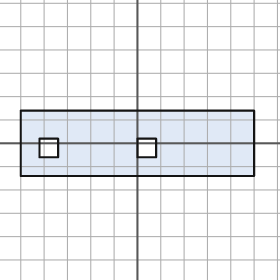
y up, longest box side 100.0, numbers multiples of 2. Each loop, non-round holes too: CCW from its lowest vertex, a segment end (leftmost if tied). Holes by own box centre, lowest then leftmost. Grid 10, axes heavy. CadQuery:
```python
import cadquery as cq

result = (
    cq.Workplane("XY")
    .moveTo(-50.0, -14.0)
    .lineTo(50.0, -14.0)
    .lineTo(50.0, 14.0)
    .lineTo(-50.0, 14.0)
    .close()
    .moveTo(-42.0, -6.0)
    .lineTo(-34.0, -6.0)
    .lineTo(-34.0, 2.0)
    .lineTo(-42.0, 2.0)
    .close()
    .moveTo(0.0, -6.0)
    .lineTo(8.0, -6.0)
    .lineTo(8.0, 2.0)
    .lineTo(0.0, 2.0)
    .close()
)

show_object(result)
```